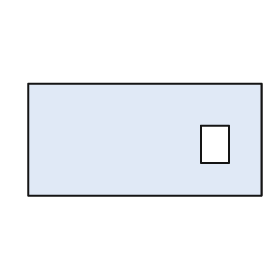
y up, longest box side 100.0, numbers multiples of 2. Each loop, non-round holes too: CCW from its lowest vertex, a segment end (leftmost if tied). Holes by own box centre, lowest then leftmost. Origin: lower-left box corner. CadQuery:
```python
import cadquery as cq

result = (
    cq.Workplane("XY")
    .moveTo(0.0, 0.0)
    .lineTo(100.0, 0.0)
    .lineTo(100.0, 48.0)
    .lineTo(0.0, 48.0)
    .close()
    .moveTo(74.0, 14.0)
    .lineTo(86.0, 14.0)
    .lineTo(86.0, 30.0)
    .lineTo(74.0, 30.0)
    .close()
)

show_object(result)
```